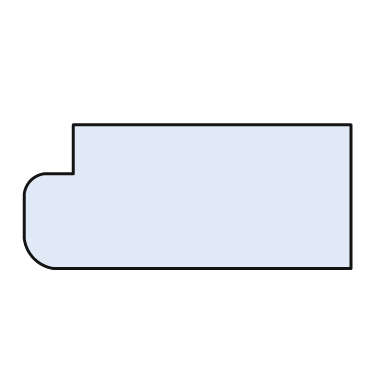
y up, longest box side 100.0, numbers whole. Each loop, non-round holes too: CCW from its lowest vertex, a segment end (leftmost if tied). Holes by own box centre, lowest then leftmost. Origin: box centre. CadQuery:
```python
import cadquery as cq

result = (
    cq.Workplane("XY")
    .moveTo(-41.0, -22.0)
    .lineTo(50.0, -22.0)
    .lineTo(50.0, 22.0)
    .lineTo(-35.0, 22.0)
    .lineTo(-35.0, 7.0)
    .lineTo(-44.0, 7.0)
    .threePointArc((-48.0, 5.0), (-50.0, 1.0))
    .lineTo(-50.0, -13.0)
    .threePointArc((-47.0, -19.0), (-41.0, -22.0))
    .close()
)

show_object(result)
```